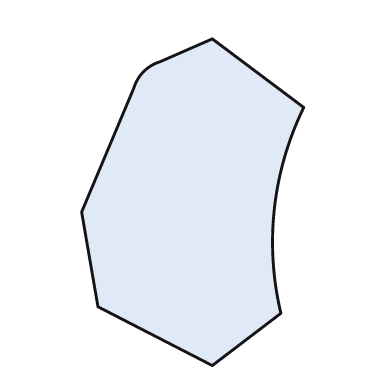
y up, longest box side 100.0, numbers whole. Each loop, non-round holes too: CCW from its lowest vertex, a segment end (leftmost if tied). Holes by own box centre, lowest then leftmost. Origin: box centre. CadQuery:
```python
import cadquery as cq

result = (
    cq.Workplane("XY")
    .moveTo(6.0, -50.0)
    .lineTo(27.0, -34.0)
    .threePointArc((25.0, -2.0), (34.0, 29.0))
    .lineTo(6.0, 50.0)
    .lineTo(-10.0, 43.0)
    .threePointArc((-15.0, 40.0), (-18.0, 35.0))
    .lineTo(-34.0, -3.0)
    .lineTo(-29.0, -32.0)
    .close()
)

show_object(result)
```